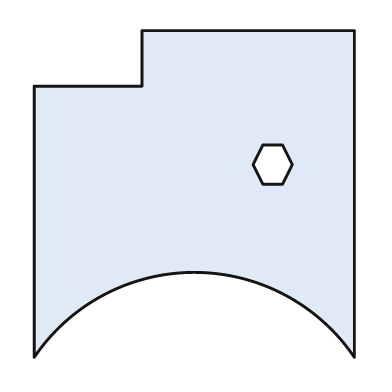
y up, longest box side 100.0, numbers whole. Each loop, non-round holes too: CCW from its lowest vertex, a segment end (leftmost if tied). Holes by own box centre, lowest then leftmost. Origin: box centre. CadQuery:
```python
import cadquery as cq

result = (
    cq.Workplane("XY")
    .moveTo(-49.0, -50.0)
    .threePointArc((0.0, -24.0), (49.0, -50.0))
    .lineTo(49.0, 50.0)
    .lineTo(-16.0, 50.0)
    .lineTo(-16.0, 33.0)
    .lineTo(-49.0, 33.0)
    .close()
    .moveTo(21.0, 3.0)
    .lineTo(27.0, 3.0)
    .lineTo(30.0, 9.0)
    .lineTo(27.0, 15.0)
    .lineTo(21.0, 15.0)
    .lineTo(18.0, 9.0)
    .close()
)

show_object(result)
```